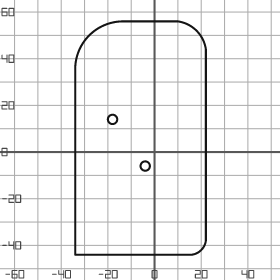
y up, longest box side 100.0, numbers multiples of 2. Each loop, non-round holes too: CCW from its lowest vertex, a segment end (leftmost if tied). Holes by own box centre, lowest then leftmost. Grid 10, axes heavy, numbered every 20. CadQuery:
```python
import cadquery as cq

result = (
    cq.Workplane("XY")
    .moveTo(-34.0, -44.0)
    .lineTo(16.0, -44.0)
    .threePointArc((20.0, -42.0), (22.0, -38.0))
    .lineTo(22.0, 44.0)
    .threePointArc((18.0, 52.0), (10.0, 56.0))
    .lineTo(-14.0, 56.0)
    .threePointArc((-28.0, 50.0), (-34.0, 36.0))
    .close()
    .moveTo(-4.0, -6.0)
    .circle(2.0)
    .moveTo(-18.0, 14.0)
    .circle(2.0)
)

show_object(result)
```